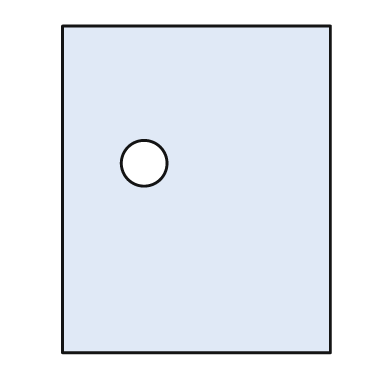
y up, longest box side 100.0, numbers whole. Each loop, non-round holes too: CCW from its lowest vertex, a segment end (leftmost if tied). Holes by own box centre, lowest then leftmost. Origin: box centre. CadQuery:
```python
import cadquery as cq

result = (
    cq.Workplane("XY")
    .moveTo(-41.0, -50.0)
    .lineTo(41.0, -50.0)
    .lineTo(41.0, 50.0)
    .lineTo(-41.0, 50.0)
    .close()
    .moveTo(-16.0, 8.0)
    .circle(7.0)
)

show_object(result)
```